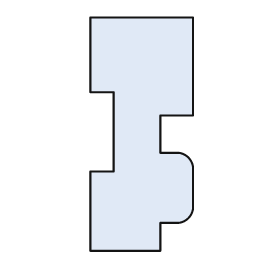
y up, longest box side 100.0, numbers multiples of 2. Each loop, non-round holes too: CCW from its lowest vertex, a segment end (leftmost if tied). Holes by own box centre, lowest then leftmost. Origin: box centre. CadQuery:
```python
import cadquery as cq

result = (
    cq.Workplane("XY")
    .moveTo(-22.0, -50.0)
    .lineTo(8.0, -50.0)
    .lineTo(8.0, -38.0)
    .lineTo(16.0, -38.0)
    .threePointArc((20.0, -36.0), (22.0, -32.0))
    .lineTo(22.0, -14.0)
    .threePointArc((20.0, -10.0), (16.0, -8.0))
    .lineTo(8.0, -8.0)
    .lineTo(8.0, 8.0)
    .lineTo(22.0, 8.0)
    .lineTo(22.0, 50.0)
    .lineTo(-22.0, 50.0)
    .lineTo(-22.0, 18.0)
    .lineTo(-12.0, 18.0)
    .lineTo(-12.0, -16.0)
    .lineTo(-22.0, -16.0)
    .close()
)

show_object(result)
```